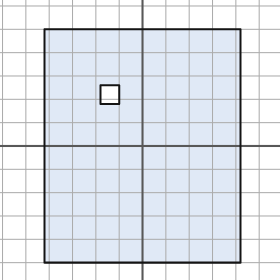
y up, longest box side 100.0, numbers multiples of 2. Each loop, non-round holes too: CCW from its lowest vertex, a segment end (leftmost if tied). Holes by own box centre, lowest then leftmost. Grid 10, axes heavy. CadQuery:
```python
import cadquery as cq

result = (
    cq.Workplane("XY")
    .moveTo(-42.0, -50.0)
    .lineTo(42.0, -50.0)
    .lineTo(42.0, 50.0)
    .lineTo(-42.0, 50.0)
    .close()
    .moveTo(-18.0, 18.0)
    .lineTo(-10.0, 18.0)
    .lineTo(-10.0, 26.0)
    .lineTo(-18.0, 26.0)
    .close()
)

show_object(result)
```